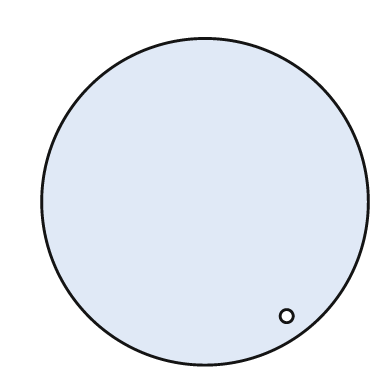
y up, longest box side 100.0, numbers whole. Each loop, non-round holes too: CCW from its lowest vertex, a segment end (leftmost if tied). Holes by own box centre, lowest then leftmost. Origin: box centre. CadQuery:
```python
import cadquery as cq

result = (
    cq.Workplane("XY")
    .moveTo(0.0, 0.0)
    .circle(50.0)
    .moveTo(25.0, -35.0)
    .circle(2.0)
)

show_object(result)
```